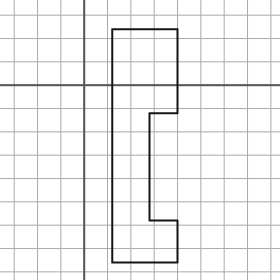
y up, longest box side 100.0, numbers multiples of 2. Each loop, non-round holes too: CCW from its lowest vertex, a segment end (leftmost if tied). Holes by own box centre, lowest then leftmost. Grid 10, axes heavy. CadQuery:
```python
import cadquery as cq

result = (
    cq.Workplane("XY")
    .moveTo(12.0, -76.0)
    .lineTo(40.0, -76.0)
    .lineTo(40.0, -58.0)
    .lineTo(28.0, -58.0)
    .lineTo(28.0, -12.0)
    .lineTo(40.0, -12.0)
    .lineTo(40.0, 24.0)
    .lineTo(12.0, 24.0)
    .close()
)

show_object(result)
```